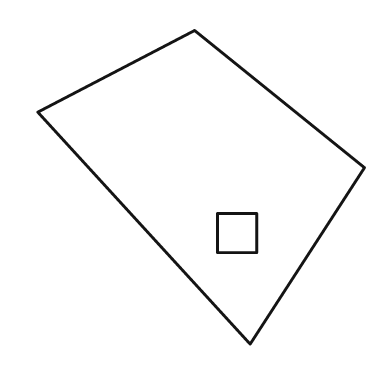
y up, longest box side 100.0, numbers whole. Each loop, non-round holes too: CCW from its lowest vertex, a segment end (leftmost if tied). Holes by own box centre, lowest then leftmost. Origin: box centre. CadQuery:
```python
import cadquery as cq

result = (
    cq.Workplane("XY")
    .moveTo(15.0, -48.0)
    .lineTo(50.0, 6.0)
    .lineTo(-2.0, 48.0)
    .lineTo(-50.0, 23.0)
    .close()
    .moveTo(5.0, -20.0)
    .lineTo(17.0, -20.0)
    .lineTo(17.0, -8.0)
    .lineTo(5.0, -8.0)
    .close()
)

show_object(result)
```